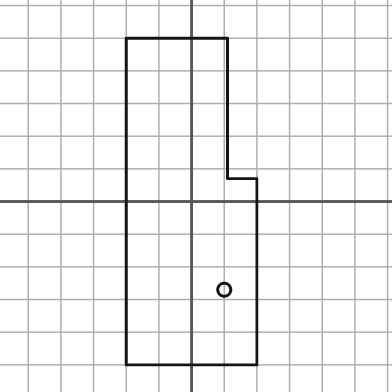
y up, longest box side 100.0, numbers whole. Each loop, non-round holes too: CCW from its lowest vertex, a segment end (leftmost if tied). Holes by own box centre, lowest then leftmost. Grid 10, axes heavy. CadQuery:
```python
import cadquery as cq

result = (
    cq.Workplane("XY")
    .moveTo(-20.0, -50.0)
    .lineTo(20.0, -50.0)
    .lineTo(20.0, 7.0)
    .lineTo(11.0, 7.0)
    .lineTo(11.0, 50.0)
    .lineTo(-20.0, 50.0)
    .close()
    .moveTo(10.0, -27.0)
    .circle(2.0)
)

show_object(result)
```